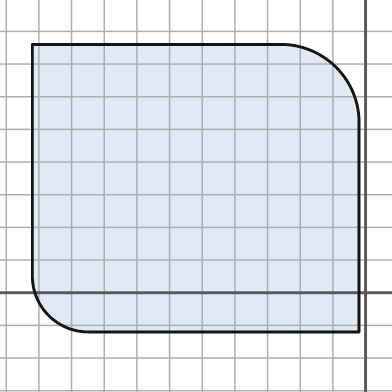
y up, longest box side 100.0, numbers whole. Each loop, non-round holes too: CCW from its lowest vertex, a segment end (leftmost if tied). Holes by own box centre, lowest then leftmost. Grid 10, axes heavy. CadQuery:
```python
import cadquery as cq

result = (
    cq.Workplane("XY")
    .moveTo(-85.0, -12.0)
    .lineTo(-2.0, -12.0)
    .lineTo(-2.0, 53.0)
    .threePointArc((-9.0, 69.0), (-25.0, 76.0))
    .lineTo(-102.0, 76.0)
    .lineTo(-102.0, 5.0)
    .threePointArc((-97.0, -7.0), (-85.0, -12.0))
    .close()
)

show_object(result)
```